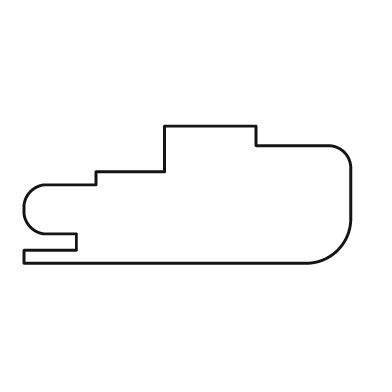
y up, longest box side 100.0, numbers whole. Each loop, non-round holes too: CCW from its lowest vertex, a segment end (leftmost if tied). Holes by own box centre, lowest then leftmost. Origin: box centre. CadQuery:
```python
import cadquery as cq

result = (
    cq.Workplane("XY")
    .moveTo(-50.0, -21.0)
    .lineTo(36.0, -21.0)
    .threePointArc((46.0, -17.0), (50.0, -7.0))
    .lineTo(50.0, 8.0)
    .threePointArc((48.0, 13.0), (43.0, 15.0))
    .lineTo(21.0, 15.0)
    .lineTo(21.0, 21.0)
    .lineTo(-7.0, 21.0)
    .lineTo(-7.0, 7.0)
    .lineTo(-28.0, 7.0)
    .lineTo(-28.0, 3.0)
    .lineTo(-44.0, 3.0)
    .threePointArc((-48.0, 1.0), (-50.0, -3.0))
    .lineTo(-50.0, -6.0)
    .threePointArc((-48.0, -10.0), (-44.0, -12.0))
    .lineTo(-34.0, -12.0)
    .lineTo(-34.0, -17.0)
    .lineTo(-50.0, -17.0)
    .close()
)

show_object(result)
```